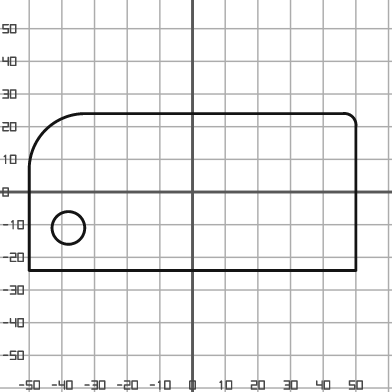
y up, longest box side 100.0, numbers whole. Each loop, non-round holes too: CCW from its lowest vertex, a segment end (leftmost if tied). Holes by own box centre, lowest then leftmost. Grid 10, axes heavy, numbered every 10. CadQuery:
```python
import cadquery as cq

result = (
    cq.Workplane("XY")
    .moveTo(-50.0, -24.0)
    .lineTo(50.0, -24.0)
    .lineTo(50.0, 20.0)
    .threePointArc((49.0, 23.0), (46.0, 24.0))
    .lineTo(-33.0, 24.0)
    .threePointArc((-45.0, 19.0), (-50.0, 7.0))
    .close()
    .moveTo(-38.0, -11.0)
    .circle(5.0)
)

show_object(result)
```